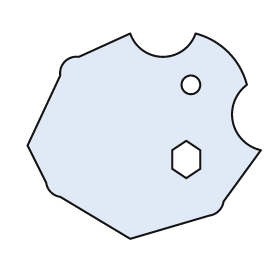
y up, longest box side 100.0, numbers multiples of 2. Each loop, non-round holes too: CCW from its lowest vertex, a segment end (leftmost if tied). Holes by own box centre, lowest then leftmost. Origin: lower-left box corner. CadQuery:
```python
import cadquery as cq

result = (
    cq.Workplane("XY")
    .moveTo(44.0, 0.0)
    .lineTo(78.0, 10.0)
    .threePointArc((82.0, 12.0), (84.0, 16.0))
    .lineTo(100.0, 38.0)
    .threePointArc((88.0, 50.0), (94.0, 66.0))
    .threePointArc((86.0, 80.0), (72.0, 88.0))
    .threePointArc((58.0, 78.0), (44.0, 88.0))
    .lineTo(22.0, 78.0)
    .threePointArc((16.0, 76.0), (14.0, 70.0))
    .lineTo(0.0, 40.0)
    .lineTo(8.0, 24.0)
    .threePointArc((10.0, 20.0), (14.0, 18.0))
    .close()
    .moveTo(68.0, 26.0)
    .lineTo(74.0, 30.0)
    .lineTo(74.0, 38.0)
    .lineTo(68.0, 42.0)
    .lineTo(62.0, 38.0)
    .lineTo(62.0, 30.0)
    .close()
    .moveTo(70.0, 66.0)
    .circle(4.0)
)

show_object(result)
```